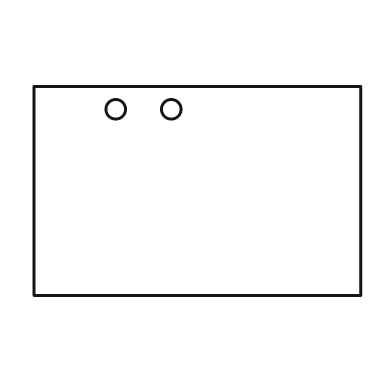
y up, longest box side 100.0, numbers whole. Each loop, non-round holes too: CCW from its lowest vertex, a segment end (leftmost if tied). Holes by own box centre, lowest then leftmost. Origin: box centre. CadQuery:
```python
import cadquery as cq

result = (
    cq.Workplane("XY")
    .moveTo(-50.0, -32.0)
    .lineTo(50.0, -32.0)
    .lineTo(50.0, 32.0)
    .lineTo(-50.0, 32.0)
    .close()
    .moveTo(-25.0, 25.0)
    .circle(3.0)
    .moveTo(-8.0, 25.0)
    .circle(3.0)
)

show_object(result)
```